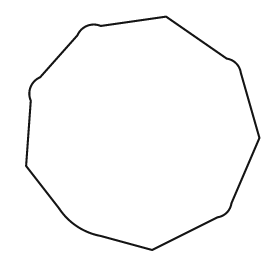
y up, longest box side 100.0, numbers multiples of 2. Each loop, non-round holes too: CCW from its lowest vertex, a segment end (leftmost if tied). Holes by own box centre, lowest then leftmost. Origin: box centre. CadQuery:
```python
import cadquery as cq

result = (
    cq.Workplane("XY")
    .moveTo(4.0, -50.0)
    .lineTo(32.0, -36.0)
    .threePointArc((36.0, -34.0), (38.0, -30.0))
    .lineTo(50.0, -2.0)
    .lineTo(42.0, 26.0)
    .threePointArc((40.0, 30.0), (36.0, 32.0))
    .lineTo(10.0, 50.0)
    .lineTo(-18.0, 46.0)
    .threePointArc((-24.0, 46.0), (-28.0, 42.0))
    .lineTo(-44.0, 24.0)
    .threePointArc((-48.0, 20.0), (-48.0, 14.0))
    .lineTo(-50.0, -14.0)
    .lineTo(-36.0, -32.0)
    .threePointArc((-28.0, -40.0), (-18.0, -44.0))
    .close()
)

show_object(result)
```